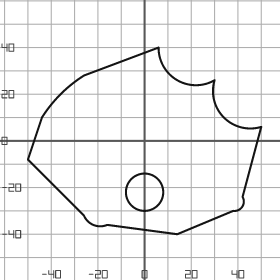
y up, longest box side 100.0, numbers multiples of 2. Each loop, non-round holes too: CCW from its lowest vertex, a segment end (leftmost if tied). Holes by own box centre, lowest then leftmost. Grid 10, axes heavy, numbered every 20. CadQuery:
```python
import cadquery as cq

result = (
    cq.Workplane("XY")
    .moveTo(14.0, -40.0)
    .lineTo(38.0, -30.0)
    .threePointArc((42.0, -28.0), (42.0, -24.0))
    .lineTo(50.0, 6.0)
    .threePointArc((34.0, 10.0), (30.0, 26.0))
    .threePointArc((14.0, 26.0), (6.0, 40.0))
    .lineTo(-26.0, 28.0)
    .threePointArc((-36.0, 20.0), (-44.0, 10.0))
    .lineTo(-50.0, -8.0)
    .lineTo(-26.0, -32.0)
    .threePointArc((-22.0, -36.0), (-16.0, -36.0))
    .close()
    .moveTo(0.0, -22.0)
    .circle(8.0)
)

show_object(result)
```